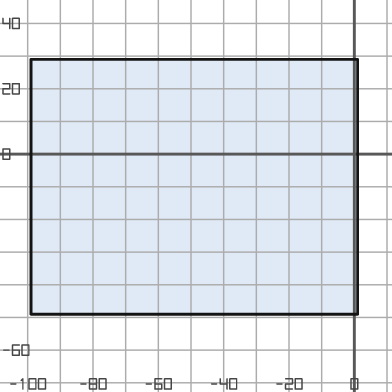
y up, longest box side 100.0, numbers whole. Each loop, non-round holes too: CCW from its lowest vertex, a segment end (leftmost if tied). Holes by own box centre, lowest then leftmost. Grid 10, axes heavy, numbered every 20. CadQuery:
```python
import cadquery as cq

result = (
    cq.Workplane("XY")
    .moveTo(-99.0, -49.0)
    .lineTo(1.0, -49.0)
    .lineTo(1.0, 29.0)
    .lineTo(-99.0, 29.0)
    .close()
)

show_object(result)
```